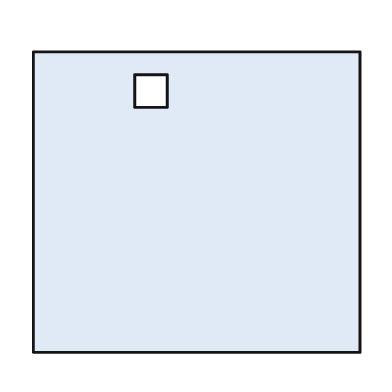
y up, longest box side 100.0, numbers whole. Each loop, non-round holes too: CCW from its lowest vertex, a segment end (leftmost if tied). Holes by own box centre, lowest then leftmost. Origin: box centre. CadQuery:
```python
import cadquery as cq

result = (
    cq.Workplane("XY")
    .moveTo(-50.0, -46.0)
    .lineTo(50.0, -46.0)
    .lineTo(50.0, 46.0)
    .lineTo(-50.0, 46.0)
    .close()
    .moveTo(-19.0, 29.0)
    .lineTo(-9.0, 29.0)
    .lineTo(-9.0, 39.0)
    .lineTo(-19.0, 39.0)
    .close()
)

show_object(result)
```